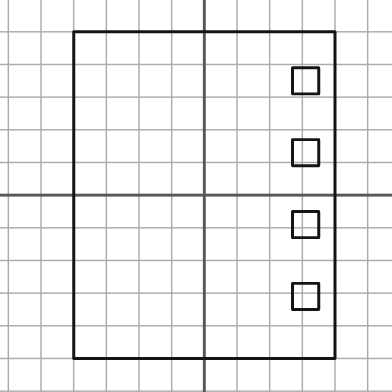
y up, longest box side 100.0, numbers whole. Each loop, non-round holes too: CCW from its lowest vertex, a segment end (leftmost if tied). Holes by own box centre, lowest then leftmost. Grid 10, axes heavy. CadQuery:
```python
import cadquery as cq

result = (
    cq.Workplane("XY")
    .moveTo(-40.0, -50.0)
    .lineTo(40.0, -50.0)
    .lineTo(40.0, 50.0)
    .lineTo(-40.0, 50.0)
    .close()
    .moveTo(27.0, -35.0)
    .lineTo(35.0, -35.0)
    .lineTo(35.0, -27.0)
    .lineTo(27.0, -27.0)
    .close()
    .moveTo(27.0, -13.0)
    .lineTo(35.0, -13.0)
    .lineTo(35.0, -5.0)
    .lineTo(27.0, -5.0)
    .close()
    .moveTo(27.0, 9.0)
    .lineTo(35.0, 9.0)
    .lineTo(35.0, 17.0)
    .lineTo(27.0, 17.0)
    .close()
    .moveTo(27.0, 31.0)
    .lineTo(35.0, 31.0)
    .lineTo(35.0, 39.0)
    .lineTo(27.0, 39.0)
    .close()
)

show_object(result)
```